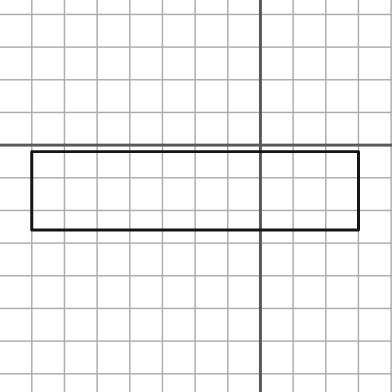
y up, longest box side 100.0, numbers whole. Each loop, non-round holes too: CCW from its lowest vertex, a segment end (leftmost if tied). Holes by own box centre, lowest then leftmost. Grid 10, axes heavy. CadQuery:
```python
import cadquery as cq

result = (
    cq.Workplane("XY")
    .moveTo(-70.0, -26.0)
    .lineTo(30.0, -26.0)
    .lineTo(30.0, -2.0)
    .lineTo(-70.0, -2.0)
    .close()
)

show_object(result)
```